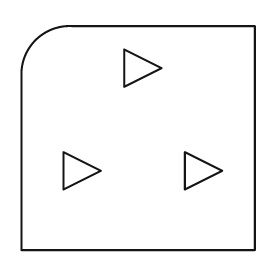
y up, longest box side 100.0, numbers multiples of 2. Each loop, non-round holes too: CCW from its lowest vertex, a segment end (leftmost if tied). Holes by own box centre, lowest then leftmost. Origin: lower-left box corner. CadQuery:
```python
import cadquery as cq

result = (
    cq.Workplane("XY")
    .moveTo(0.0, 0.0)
    .lineTo(100.0, 0.0)
    .lineTo(100.0, 96.0)
    .lineTo(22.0, 96.0)
    .threePointArc((6.0, 90.0), (0.0, 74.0))
    .close()
    .moveTo(18.0, 26.0)
    .lineTo(34.0, 34.0)
    .lineTo(18.0, 42.0)
    .close()
    .moveTo(70.0, 26.0)
    .lineTo(86.0, 34.0)
    .lineTo(70.0, 42.0)
    .close()
    .moveTo(44.0, 70.0)
    .lineTo(60.0, 78.0)
    .lineTo(44.0, 86.0)
    .close()
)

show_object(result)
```